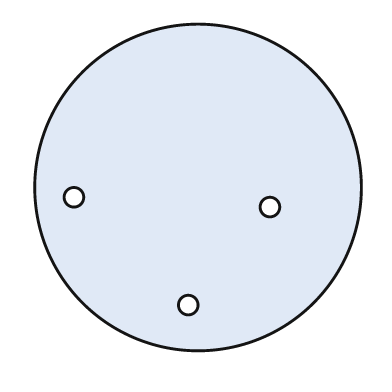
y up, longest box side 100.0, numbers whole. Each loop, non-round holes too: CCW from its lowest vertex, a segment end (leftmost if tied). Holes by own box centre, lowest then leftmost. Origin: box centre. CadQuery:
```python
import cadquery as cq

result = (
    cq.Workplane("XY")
    .moveTo(0.0, 0.0)
    .circle(50.0)
    .moveTo(-3.0, -36.0)
    .circle(3.0)
    .moveTo(22.0, -6.0)
    .circle(3.0)
    .moveTo(-38.0, -3.0)
    .circle(3.0)
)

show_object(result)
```